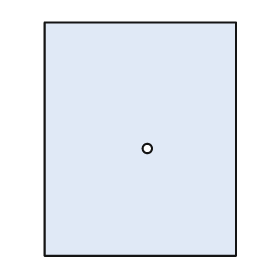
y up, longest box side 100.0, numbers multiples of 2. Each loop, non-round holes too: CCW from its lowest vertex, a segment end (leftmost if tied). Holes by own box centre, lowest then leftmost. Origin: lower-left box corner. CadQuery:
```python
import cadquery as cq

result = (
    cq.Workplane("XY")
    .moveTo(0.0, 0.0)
    .lineTo(82.0, 0.0)
    .lineTo(82.0, 100.0)
    .lineTo(0.0, 100.0)
    .close()
    .moveTo(44.0, 46.0)
    .circle(2.0)
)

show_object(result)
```